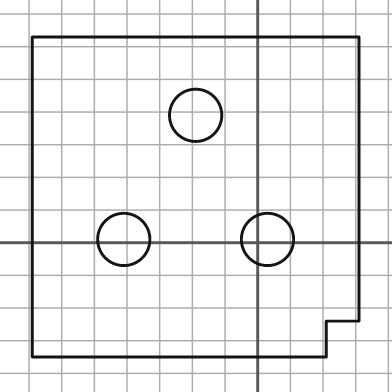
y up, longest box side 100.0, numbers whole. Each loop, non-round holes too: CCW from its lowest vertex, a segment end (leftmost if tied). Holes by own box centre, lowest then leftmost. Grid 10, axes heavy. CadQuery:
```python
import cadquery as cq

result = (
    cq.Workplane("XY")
    .moveTo(-69.0, -35.0)
    .lineTo(21.0, -35.0)
    .lineTo(21.0, -24.0)
    .lineTo(31.0, -24.0)
    .lineTo(31.0, 63.0)
    .lineTo(-69.0, 63.0)
    .close()
    .moveTo(-41.0, 1.0)
    .circle(8.0)
    .moveTo(3.0, 1.0)
    .circle(8.0)
    .moveTo(-19.0, 39.0)
    .circle(8.0)
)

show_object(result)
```